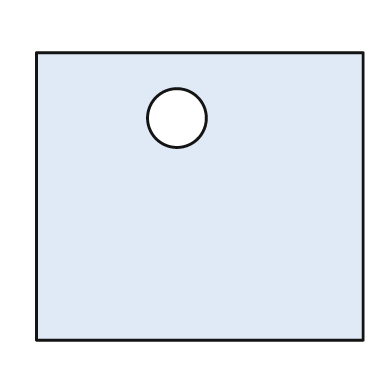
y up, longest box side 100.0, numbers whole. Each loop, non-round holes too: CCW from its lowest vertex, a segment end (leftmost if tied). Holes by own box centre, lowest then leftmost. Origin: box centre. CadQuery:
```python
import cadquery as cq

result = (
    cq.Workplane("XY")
    .moveTo(-50.0, -44.0)
    .lineTo(50.0, -44.0)
    .lineTo(50.0, 44.0)
    .lineTo(-50.0, 44.0)
    .close()
    .moveTo(-7.0, 24.0)
    .circle(9.0)
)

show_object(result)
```